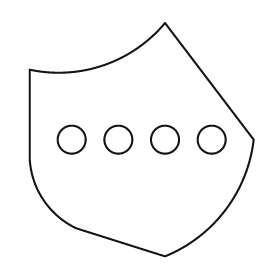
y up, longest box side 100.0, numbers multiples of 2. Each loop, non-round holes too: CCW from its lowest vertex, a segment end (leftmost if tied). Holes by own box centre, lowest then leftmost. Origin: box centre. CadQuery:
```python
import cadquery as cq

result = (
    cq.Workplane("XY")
    .moveTo(10.0, -50.0)
    .threePointArc((36.0, -30.0), (48.0, 0.0))
    .lineTo(10.0, 50.0)
    .threePointArc((-16.0, 32.0), (-48.0, 30.0))
    .lineTo(-48.0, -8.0)
    .threePointArc((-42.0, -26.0), (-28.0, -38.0))
    .close()
    .moveTo(-30.0, 0.0)
    .circle(6.0)
    .moveTo(-10.0, 0.0)
    .circle(6.0)
    .moveTo(10.0, 0.0)
    .circle(6.0)
    .moveTo(30.0, 0.0)
    .circle(6.0)
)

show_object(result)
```